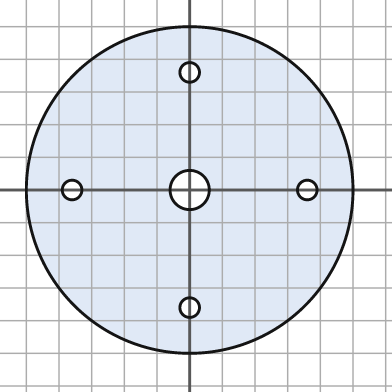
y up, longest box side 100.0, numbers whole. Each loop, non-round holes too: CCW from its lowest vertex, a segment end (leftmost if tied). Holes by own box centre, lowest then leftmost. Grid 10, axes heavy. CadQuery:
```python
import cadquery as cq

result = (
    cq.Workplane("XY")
    .moveTo(0.0, 0.0)
    .circle(50.0)
    .moveTo(0.0, -36.0)
    .circle(3.0)
    .moveTo(-36.0, 0.0)
    .circle(3.0)
    .moveTo(0.0, 0.0)
    .circle(6.0)
    .moveTo(36.0, 0.0)
    .circle(3.0)
    .moveTo(0.0, 36.0)
    .circle(3.0)
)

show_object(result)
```